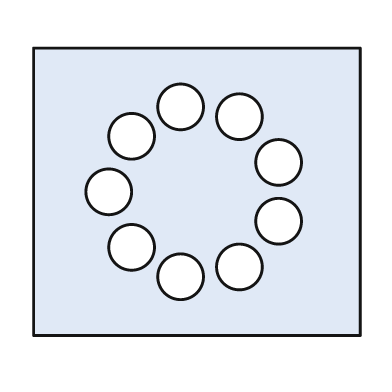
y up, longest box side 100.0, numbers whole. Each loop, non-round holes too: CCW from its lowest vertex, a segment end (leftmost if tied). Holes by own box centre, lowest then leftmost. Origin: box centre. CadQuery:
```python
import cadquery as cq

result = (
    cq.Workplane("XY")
    .moveTo(-50.0, -44.0)
    .lineTo(50.0, -44.0)
    .lineTo(50.0, 44.0)
    .lineTo(-50.0, 44.0)
    .close()
    .moveTo(-5.0, -26.0)
    .circle(7.0)
    .moveTo(13.0, -23.0)
    .circle(7.0)
    .moveTo(-20.0, -17.0)
    .circle(7.0)
    .moveTo(25.0, -9.0)
    .circle(7.0)
    .moveTo(-27.0, 0.0)
    .circle(7.0)
    .moveTo(25.0, 9.0)
    .circle(7.0)
    .moveTo(-20.0, 17.0)
    .circle(7.0)
    .moveTo(13.0, 23.0)
    .circle(7.0)
    .moveTo(-5.0, 26.0)
    .circle(7.0)
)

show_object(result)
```